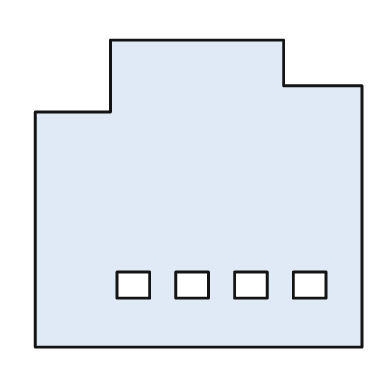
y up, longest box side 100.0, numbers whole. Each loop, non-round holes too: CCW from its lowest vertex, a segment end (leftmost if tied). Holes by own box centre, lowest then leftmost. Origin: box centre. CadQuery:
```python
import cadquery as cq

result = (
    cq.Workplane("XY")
    .moveTo(-50.0, -47.0)
    .lineTo(50.0, -47.0)
    .lineTo(50.0, 33.0)
    .lineTo(26.0, 33.0)
    .lineTo(26.0, 47.0)
    .lineTo(-27.0, 47.0)
    .lineTo(-27.0, 25.0)
    .lineTo(-50.0, 25.0)
    .close()
    .moveTo(-25.0, -32.0)
    .lineTo(-15.0, -32.0)
    .lineTo(-15.0, -24.0)
    .lineTo(-25.0, -24.0)
    .close()
    .moveTo(-7.0, -32.0)
    .lineTo(3.0, -32.0)
    .lineTo(3.0, -24.0)
    .lineTo(-7.0, -24.0)
    .close()
    .moveTo(11.0, -32.0)
    .lineTo(21.0, -32.0)
    .lineTo(21.0, -24.0)
    .lineTo(11.0, -24.0)
    .close()
    .moveTo(29.0, -32.0)
    .lineTo(39.0, -32.0)
    .lineTo(39.0, -24.0)
    .lineTo(29.0, -24.0)
    .close()
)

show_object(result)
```